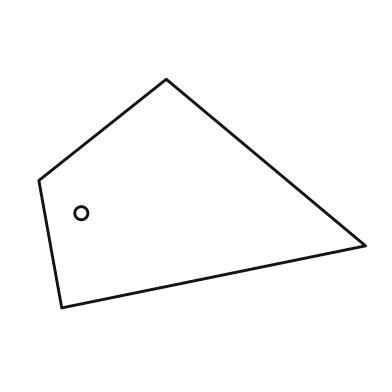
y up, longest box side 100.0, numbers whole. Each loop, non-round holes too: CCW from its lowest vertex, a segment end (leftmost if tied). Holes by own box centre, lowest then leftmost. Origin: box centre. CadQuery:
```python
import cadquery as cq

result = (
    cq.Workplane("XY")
    .moveTo(-43.0, -35.0)
    .lineTo(50.0, -16.0)
    .lineTo(-11.0, 35.0)
    .lineTo(-50.0, 4.0)
    .close()
    .moveTo(-37.0, -6.0)
    .circle(2.0)
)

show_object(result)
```